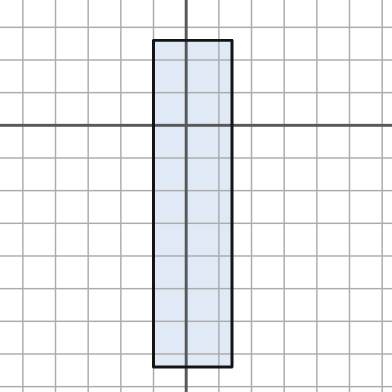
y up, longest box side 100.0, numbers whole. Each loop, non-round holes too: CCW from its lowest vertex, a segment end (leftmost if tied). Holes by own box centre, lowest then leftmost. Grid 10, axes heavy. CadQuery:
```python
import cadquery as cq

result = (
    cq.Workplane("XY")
    .moveTo(-10.0, -74.0)
    .lineTo(14.0, -74.0)
    .lineTo(14.0, 26.0)
    .lineTo(-10.0, 26.0)
    .close()
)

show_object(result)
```